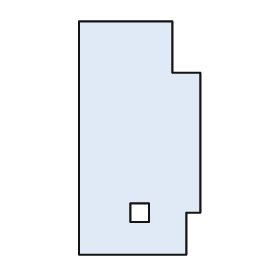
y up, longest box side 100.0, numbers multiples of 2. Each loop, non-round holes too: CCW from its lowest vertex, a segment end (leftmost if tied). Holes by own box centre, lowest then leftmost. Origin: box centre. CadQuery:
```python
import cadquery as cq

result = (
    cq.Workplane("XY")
    .moveTo(-26.0, -50.0)
    .lineTo(20.0, -50.0)
    .lineTo(20.0, -32.0)
    .lineTo(26.0, -32.0)
    .lineTo(26.0, 28.0)
    .lineTo(14.0, 28.0)
    .lineTo(14.0, 50.0)
    .lineTo(-26.0, 50.0)
    .close()
    .moveTo(-4.0, -36.0)
    .lineTo(4.0, -36.0)
    .lineTo(4.0, -28.0)
    .lineTo(-4.0, -28.0)
    .close()
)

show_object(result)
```